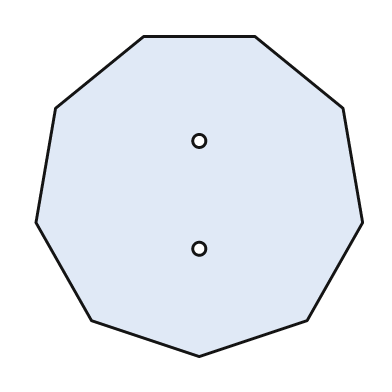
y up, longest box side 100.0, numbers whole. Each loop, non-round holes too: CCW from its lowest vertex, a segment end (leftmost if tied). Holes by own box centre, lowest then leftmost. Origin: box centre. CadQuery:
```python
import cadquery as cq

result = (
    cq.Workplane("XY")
    .moveTo(0.0, -49.0)
    .lineTo(33.0, -38.0)
    .lineTo(50.0, -8.0)
    .lineTo(44.0, 27.0)
    .lineTo(17.0, 49.0)
    .lineTo(-17.0, 49.0)
    .lineTo(-44.0, 27.0)
    .lineTo(-50.0, -8.0)
    .lineTo(-33.0, -38.0)
    .close()
    .moveTo(0.0, -16.0)
    .circle(2.0)
    .moveTo(0.0, 17.0)
    .circle(2.0)
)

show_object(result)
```